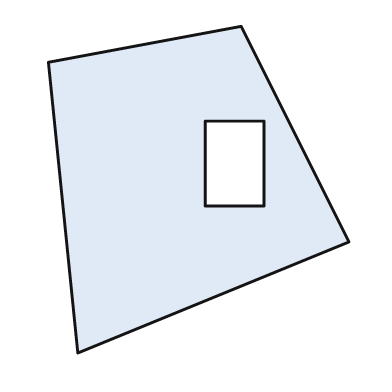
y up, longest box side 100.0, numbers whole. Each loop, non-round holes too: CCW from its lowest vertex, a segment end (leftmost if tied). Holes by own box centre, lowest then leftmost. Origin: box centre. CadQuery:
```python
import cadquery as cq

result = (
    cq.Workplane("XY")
    .moveTo(-37.0, -50.0)
    .lineTo(46.0, -16.0)
    .lineTo(13.0, 50.0)
    .lineTo(-46.0, 39.0)
    .close()
    .moveTo(2.0, -5.0)
    .lineTo(20.0, -5.0)
    .lineTo(20.0, 21.0)
    .lineTo(2.0, 21.0)
    .close()
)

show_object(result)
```